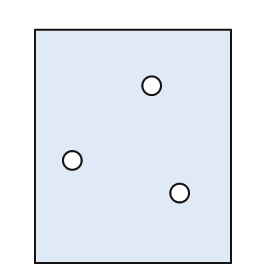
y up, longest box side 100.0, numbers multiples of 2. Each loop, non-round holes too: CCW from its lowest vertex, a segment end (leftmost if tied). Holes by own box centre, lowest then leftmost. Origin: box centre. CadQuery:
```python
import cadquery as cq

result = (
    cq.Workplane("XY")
    .moveTo(-42.0, -50.0)
    .lineTo(42.0, -50.0)
    .lineTo(42.0, 50.0)
    .lineTo(-42.0, 50.0)
    .close()
    .moveTo(20.0, -20.0)
    .circle(4.0)
    .moveTo(-26.0, -6.0)
    .circle(4.0)
    .moveTo(8.0, 26.0)
    .circle(4.0)
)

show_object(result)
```